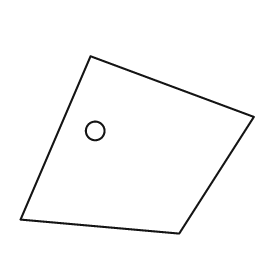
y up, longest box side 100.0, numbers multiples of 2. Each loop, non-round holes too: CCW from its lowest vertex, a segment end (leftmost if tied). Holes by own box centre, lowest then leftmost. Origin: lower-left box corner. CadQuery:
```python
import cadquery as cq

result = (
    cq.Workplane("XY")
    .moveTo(68.0, 0.0)
    .lineTo(100.0, 50.0)
    .lineTo(30.0, 76.0)
    .lineTo(0.0, 6.0)
    .close()
    .moveTo(32.0, 44.0)
    .circle(4.0)
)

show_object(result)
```